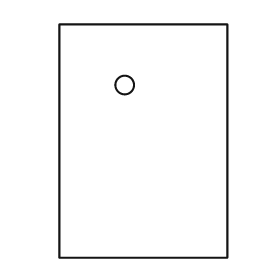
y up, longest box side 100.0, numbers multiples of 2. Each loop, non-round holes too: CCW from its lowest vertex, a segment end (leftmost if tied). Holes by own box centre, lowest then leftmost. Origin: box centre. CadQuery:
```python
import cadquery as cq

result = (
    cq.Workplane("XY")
    .moveTo(-36.0, -50.0)
    .lineTo(36.0, -50.0)
    .lineTo(36.0, 50.0)
    .lineTo(-36.0, 50.0)
    .close()
    .moveTo(-8.0, 24.0)
    .circle(4.0)
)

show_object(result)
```